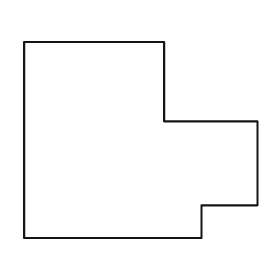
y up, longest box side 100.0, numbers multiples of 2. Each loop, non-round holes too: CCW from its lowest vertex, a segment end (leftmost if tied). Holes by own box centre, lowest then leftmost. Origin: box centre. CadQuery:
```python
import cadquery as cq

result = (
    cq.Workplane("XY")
    .moveTo(-50.0, -42.0)
    .lineTo(26.0, -42.0)
    .lineTo(26.0, -28.0)
    .lineTo(50.0, -28.0)
    .lineTo(50.0, 8.0)
    .lineTo(10.0, 8.0)
    .lineTo(10.0, 42.0)
    .lineTo(-50.0, 42.0)
    .close()
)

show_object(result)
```